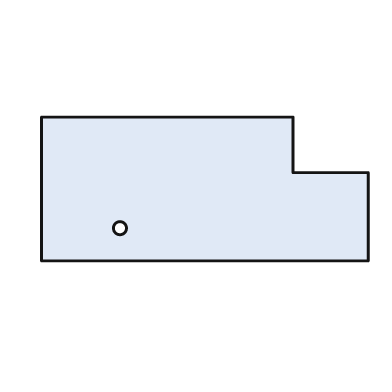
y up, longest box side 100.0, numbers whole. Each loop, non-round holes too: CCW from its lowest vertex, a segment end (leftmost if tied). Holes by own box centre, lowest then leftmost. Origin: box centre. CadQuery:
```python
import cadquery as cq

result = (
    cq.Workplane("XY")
    .moveTo(-50.0, -22.0)
    .lineTo(50.0, -22.0)
    .lineTo(50.0, 5.0)
    .lineTo(27.0, 5.0)
    .lineTo(27.0, 22.0)
    .lineTo(-50.0, 22.0)
    .close()
    .moveTo(-26.0, -12.0)
    .circle(2.0)
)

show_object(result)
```